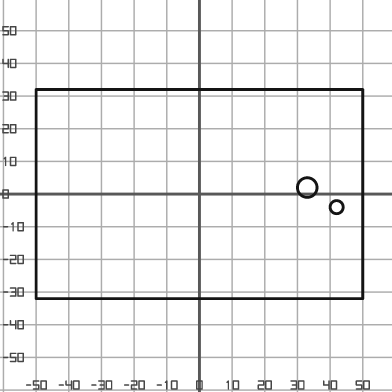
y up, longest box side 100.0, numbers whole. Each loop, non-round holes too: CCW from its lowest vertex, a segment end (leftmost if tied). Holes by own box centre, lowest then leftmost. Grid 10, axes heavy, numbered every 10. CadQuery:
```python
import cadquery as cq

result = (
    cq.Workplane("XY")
    .moveTo(-50.0, -32.0)
    .lineTo(50.0, -32.0)
    .lineTo(50.0, 32.0)
    .lineTo(-50.0, 32.0)
    .close()
    .moveTo(42.0, -4.0)
    .circle(2.0)
    .moveTo(33.0, 2.0)
    .circle(3.0)
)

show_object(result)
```